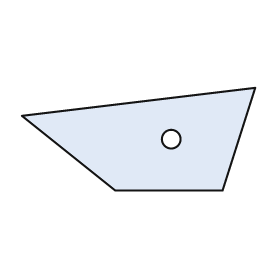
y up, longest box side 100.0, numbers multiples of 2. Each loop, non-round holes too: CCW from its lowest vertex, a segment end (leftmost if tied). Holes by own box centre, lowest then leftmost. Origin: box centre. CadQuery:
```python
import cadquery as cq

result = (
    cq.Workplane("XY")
    .moveTo(-10.0, -22.0)
    .lineTo(36.0, -22.0)
    .lineTo(50.0, 22.0)
    .lineTo(-50.0, 10.0)
    .close()
    .moveTo(14.0, 0.0)
    .circle(4.0)
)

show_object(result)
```